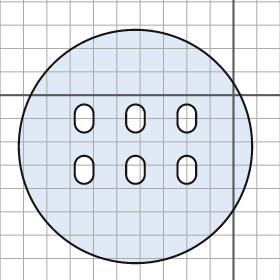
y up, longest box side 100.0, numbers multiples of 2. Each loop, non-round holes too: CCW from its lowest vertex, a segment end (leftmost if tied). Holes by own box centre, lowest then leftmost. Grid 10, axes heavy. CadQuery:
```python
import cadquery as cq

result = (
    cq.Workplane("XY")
    .moveTo(-42.0, -22.0)
    .circle(50.0)
    .moveTo(-68.0, -34.0)
    .threePointArc((-64.0, -38.0), (-60.0, -34.0))
    .lineTo(-60.0, -30.0)
    .threePointArc((-64.0, -26.0), (-68.0, -30.0))
    .close()
    .moveTo(-46.0, -34.0)
    .threePointArc((-42.0, -38.0), (-38.0, -34.0))
    .lineTo(-38.0, -30.0)
    .threePointArc((-42.0, -26.0), (-46.0, -30.0))
    .close()
    .moveTo(-24.0, -34.0)
    .threePointArc((-20.0, -38.0), (-16.0, -34.0))
    .lineTo(-16.0, -30.0)
    .threePointArc((-20.0, -26.0), (-24.0, -30.0))
    .close()
    .moveTo(-68.0, -12.0)
    .threePointArc((-64.0, -16.0), (-60.0, -12.0))
    .lineTo(-60.0, -8.0)
    .threePointArc((-64.0, -4.0), (-68.0, -8.0))
    .close()
    .moveTo(-46.0, -12.0)
    .threePointArc((-42.0, -16.0), (-38.0, -12.0))
    .lineTo(-38.0, -8.0)
    .threePointArc((-42.0, -4.0), (-46.0, -8.0))
    .close()
    .moveTo(-24.0, -12.0)
    .threePointArc((-20.0, -16.0), (-16.0, -12.0))
    .lineTo(-16.0, -8.0)
    .threePointArc((-20.0, -4.0), (-24.0, -8.0))
    .close()
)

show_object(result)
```